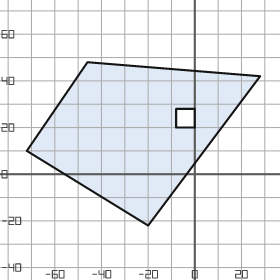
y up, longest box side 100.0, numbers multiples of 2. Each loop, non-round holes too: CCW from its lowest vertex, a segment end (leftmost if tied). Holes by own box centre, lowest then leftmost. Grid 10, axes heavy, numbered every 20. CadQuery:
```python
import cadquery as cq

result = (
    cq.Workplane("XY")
    .moveTo(-20.0, -22.0)
    .lineTo(28.0, 42.0)
    .lineTo(-46.0, 48.0)
    .lineTo(-72.0, 10.0)
    .close()
    .moveTo(-8.0, 20.0)
    .lineTo(0.0, 20.0)
    .lineTo(0.0, 28.0)
    .lineTo(-8.0, 28.0)
    .close()
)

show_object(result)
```